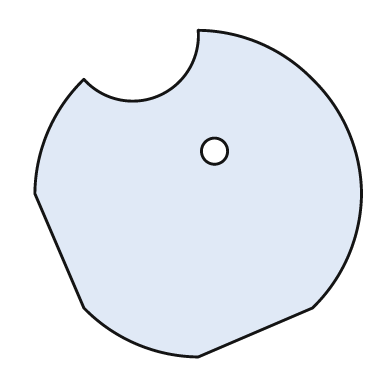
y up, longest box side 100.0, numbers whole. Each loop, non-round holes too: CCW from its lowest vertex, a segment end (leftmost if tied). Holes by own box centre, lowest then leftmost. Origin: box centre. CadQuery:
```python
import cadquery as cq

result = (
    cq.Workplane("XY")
    .moveTo(0.0, -50.0)
    .lineTo(35.0, -35.0)
    .threePointArc((46.0, -19.0), (50.0, 0.0))
    .threePointArc((46.0, 19.0), (35.0, 35.0))
    .threePointArc((19.0, 46.0), (0.0, 50.0))
    .threePointArc((-12.0, 30.0), (-35.0, 35.0))
    .threePointArc((-46.0, 19.0), (-50.0, 0.0))
    .lineTo(-35.0, -35.0)
    .threePointArc((-19.0, -46.0), (0.0, -50.0))
    .close()
    .moveTo(5.0, 13.0)
    .circle(4.0)
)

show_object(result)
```